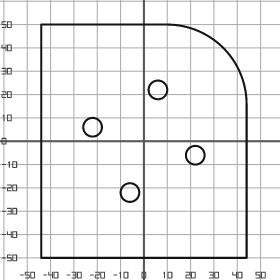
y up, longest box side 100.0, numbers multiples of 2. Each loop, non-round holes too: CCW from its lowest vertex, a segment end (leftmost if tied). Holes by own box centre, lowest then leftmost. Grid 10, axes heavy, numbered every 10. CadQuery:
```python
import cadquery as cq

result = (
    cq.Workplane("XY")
    .moveTo(-44.0, -50.0)
    .lineTo(44.0, -50.0)
    .lineTo(44.0, 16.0)
    .threePointArc((34.0, 40.0), (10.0, 50.0))
    .lineTo(-44.0, 50.0)
    .close()
    .moveTo(-6.0, -22.0)
    .circle(4.0)
    .moveTo(22.0, -6.0)
    .circle(4.0)
    .moveTo(-22.0, 6.0)
    .circle(4.0)
    .moveTo(6.0, 22.0)
    .circle(4.0)
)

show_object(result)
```